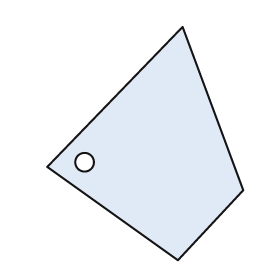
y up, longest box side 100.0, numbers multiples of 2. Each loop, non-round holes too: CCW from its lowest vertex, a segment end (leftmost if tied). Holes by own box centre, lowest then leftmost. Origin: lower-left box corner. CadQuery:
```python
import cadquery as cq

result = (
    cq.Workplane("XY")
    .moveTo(56.0, 0.0)
    .lineTo(84.0, 30.0)
    .lineTo(58.0, 100.0)
    .lineTo(0.0, 40.0)
    .close()
    .moveTo(16.0, 42.0)
    .circle(4.0)
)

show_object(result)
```